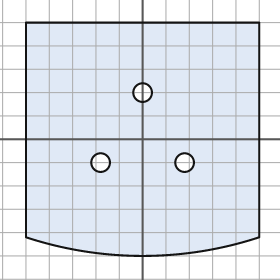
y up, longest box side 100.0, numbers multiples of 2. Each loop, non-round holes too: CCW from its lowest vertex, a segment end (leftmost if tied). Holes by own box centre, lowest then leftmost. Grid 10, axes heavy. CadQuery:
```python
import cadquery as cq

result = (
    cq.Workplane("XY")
    .moveTo(-50.0, -42.0)
    .threePointArc((0.0, -50.0), (50.0, -42.0))
    .lineTo(50.0, 50.0)
    .lineTo(-50.0, 50.0)
    .close()
    .moveTo(-18.0, -10.0)
    .circle(4.0)
    .moveTo(18.0, -10.0)
    .circle(4.0)
    .moveTo(0.0, 20.0)
    .circle(4.0)
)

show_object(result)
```